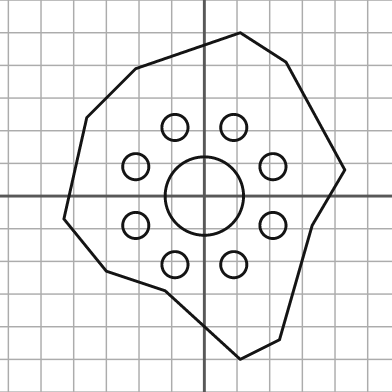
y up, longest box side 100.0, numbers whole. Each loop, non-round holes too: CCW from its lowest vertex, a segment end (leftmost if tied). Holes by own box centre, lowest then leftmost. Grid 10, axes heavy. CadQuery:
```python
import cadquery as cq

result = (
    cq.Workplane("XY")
    .moveTo(11.0, -50.0)
    .lineTo(23.0, -44.0)
    .lineTo(33.0, -9.0)
    .lineTo(43.0, 8.0)
    .lineTo(25.0, 41.0)
    .lineTo(11.0, 50.0)
    .lineTo(-21.0, 39.0)
    .lineTo(-36.0, 24.0)
    .lineTo(-43.0, -7.0)
    .lineTo(-30.0, -23.0)
    .lineTo(-12.0, -29.0)
    .close()
    .moveTo(-9.0, -21.0)
    .circle(4.0)
    .moveTo(9.0, -21.0)
    .circle(4.0)
    .moveTo(-21.0, -9.0)
    .circle(4.0)
    .moveTo(21.0, -9.0)
    .circle(4.0)
    .moveTo(0.0, 0.0)
    .circle(12.0)
    .moveTo(-21.0, 9.0)
    .circle(4.0)
    .moveTo(21.0, 9.0)
    .circle(4.0)
    .moveTo(-9.0, 21.0)
    .circle(4.0)
    .moveTo(9.0, 21.0)
    .circle(4.0)
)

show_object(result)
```